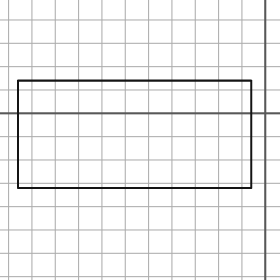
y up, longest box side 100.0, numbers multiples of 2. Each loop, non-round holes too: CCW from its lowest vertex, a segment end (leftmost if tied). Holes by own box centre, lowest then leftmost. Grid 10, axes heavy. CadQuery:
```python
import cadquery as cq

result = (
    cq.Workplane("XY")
    .moveTo(-106.0, -32.0)
    .lineTo(-6.0, -32.0)
    .lineTo(-6.0, 14.0)
    .lineTo(-106.0, 14.0)
    .close()
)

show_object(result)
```